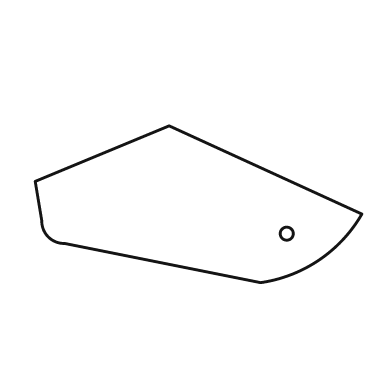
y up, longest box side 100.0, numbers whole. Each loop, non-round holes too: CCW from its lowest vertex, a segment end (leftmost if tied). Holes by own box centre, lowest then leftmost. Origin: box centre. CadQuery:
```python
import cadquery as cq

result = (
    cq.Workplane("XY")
    .moveTo(19.0, -24.0)
    .threePointArc((37.0, -17.0), (50.0, -3.0))
    .lineTo(-9.0, 24.0)
    .lineTo(-50.0, 7.0)
    .lineTo(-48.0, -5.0)
    .threePointArc((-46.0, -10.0), (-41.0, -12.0))
    .close()
    .moveTo(27.0, -9.0)
    .circle(2.0)
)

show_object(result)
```